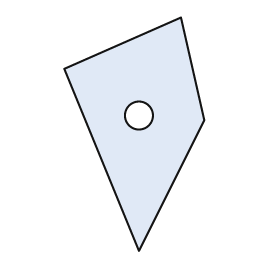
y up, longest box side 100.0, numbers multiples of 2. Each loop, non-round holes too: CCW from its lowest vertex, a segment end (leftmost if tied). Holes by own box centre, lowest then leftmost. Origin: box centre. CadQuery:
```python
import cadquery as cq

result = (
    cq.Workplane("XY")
    .moveTo(2.0, -50.0)
    .lineTo(30.0, 6.0)
    .lineTo(20.0, 50.0)
    .lineTo(-30.0, 28.0)
    .close()
    .moveTo(2.0, 8.0)
    .circle(6.0)
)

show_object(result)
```